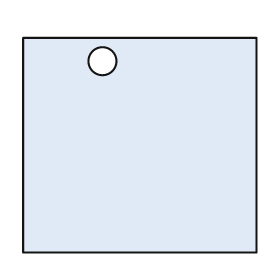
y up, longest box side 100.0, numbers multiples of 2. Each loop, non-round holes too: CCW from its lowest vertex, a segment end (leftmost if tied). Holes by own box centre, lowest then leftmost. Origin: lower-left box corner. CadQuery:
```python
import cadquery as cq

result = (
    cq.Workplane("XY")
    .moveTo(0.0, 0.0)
    .lineTo(100.0, 0.0)
    .lineTo(100.0, 92.0)
    .lineTo(0.0, 92.0)
    .close()
    .moveTo(34.0, 82.0)
    .circle(6.0)
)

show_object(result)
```